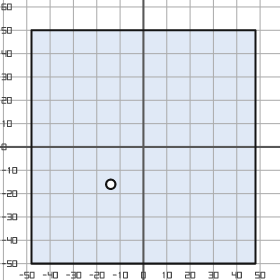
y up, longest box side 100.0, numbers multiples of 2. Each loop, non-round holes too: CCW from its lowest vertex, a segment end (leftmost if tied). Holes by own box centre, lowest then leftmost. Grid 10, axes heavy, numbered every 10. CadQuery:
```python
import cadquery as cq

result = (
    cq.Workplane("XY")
    .moveTo(-48.0, -50.0)
    .lineTo(48.0, -50.0)
    .lineTo(48.0, 50.0)
    .lineTo(-48.0, 50.0)
    .close()
    .moveTo(-14.0, -16.0)
    .circle(2.0)
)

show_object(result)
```